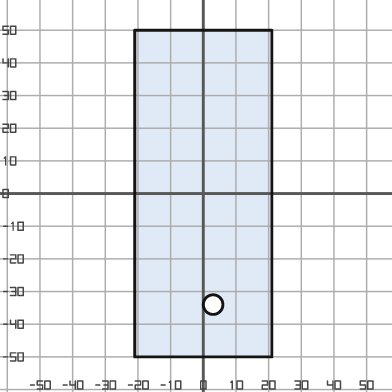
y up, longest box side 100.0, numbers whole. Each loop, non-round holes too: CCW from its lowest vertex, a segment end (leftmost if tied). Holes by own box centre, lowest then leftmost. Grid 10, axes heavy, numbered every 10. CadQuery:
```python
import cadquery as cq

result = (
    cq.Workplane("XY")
    .moveTo(-21.0, -50.0)
    .lineTo(21.0, -50.0)
    .lineTo(21.0, 50.0)
    .lineTo(-21.0, 50.0)
    .close()
    .moveTo(3.0, -34.0)
    .circle(3.0)
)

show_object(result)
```